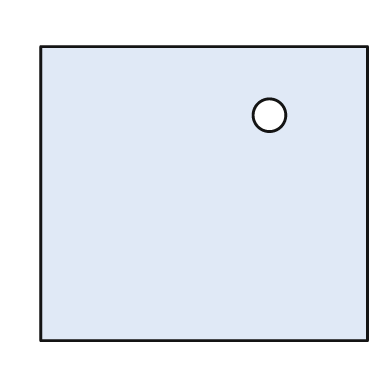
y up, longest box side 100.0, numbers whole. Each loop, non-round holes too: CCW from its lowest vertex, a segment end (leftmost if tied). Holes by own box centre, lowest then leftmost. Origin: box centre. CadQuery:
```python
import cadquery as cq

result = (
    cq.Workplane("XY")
    .moveTo(-50.0, -45.0)
    .lineTo(50.0, -45.0)
    .lineTo(50.0, 45.0)
    .lineTo(-50.0, 45.0)
    .close()
    .moveTo(20.0, 24.0)
    .circle(5.0)
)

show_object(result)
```